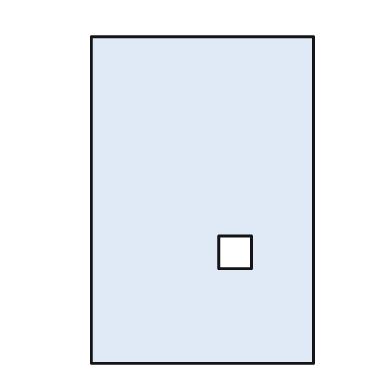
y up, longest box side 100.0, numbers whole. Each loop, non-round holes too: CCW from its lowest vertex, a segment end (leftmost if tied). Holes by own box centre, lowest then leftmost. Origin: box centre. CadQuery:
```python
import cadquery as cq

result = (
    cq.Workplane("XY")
    .moveTo(-34.0, -50.0)
    .lineTo(34.0, -50.0)
    .lineTo(34.0, 50.0)
    .lineTo(-34.0, 50.0)
    .close()
    .moveTo(5.0, -21.0)
    .lineTo(15.0, -21.0)
    .lineTo(15.0, -11.0)
    .lineTo(5.0, -11.0)
    .close()
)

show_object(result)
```